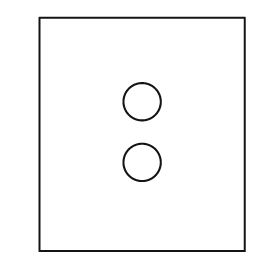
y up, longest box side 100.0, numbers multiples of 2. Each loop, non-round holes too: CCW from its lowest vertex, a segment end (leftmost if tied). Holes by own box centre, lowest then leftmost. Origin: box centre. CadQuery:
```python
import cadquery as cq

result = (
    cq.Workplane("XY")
    .moveTo(-44.0, -50.0)
    .lineTo(44.0, -50.0)
    .lineTo(44.0, 50.0)
    .lineTo(-44.0, 50.0)
    .close()
    .moveTo(0.0, -12.0)
    .circle(8.0)
    .moveTo(0.0, 14.0)
    .circle(8.0)
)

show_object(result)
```